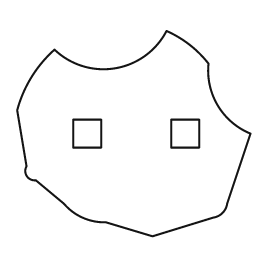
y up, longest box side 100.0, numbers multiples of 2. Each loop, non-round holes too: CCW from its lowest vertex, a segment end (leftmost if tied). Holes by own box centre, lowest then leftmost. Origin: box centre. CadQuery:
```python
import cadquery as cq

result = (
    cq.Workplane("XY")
    .moveTo(8.0, -44.0)
    .lineTo(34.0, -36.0)
    .threePointArc((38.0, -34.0), (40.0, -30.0))
    .lineTo(50.0, 0.0)
    .threePointArc((36.0, 12.0), (32.0, 30.0))
    .threePointArc((24.0, 38.0), (14.0, 44.0))
    .threePointArc((-8.0, 28.0), (-34.0, 36.0))
    .threePointArc((-44.0, 24.0), (-50.0, 10.0))
    .lineTo(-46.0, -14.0)
    .threePointArc((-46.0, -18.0), (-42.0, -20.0))
    .lineTo(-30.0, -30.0)
    .threePointArc((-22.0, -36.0), (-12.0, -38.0))
    .close()
    .moveTo(-26.0, -6.0)
    .lineTo(-14.0, -6.0)
    .lineTo(-14.0, 6.0)
    .lineTo(-26.0, 6.0)
    .close()
    .moveTo(16.0, -6.0)
    .lineTo(28.0, -6.0)
    .lineTo(28.0, 6.0)
    .lineTo(16.0, 6.0)
    .close()
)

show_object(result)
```